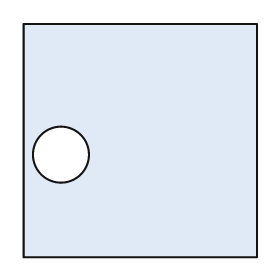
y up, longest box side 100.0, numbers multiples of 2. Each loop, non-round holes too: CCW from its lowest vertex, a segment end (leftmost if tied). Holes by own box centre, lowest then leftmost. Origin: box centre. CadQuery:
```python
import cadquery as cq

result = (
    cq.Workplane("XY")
    .moveTo(-50.0, -50.0)
    .lineTo(50.0, -50.0)
    .lineTo(50.0, 50.0)
    .lineTo(-50.0, 50.0)
    .close()
    .moveTo(-34.0, -6.0)
    .circle(12.0)
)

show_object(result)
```